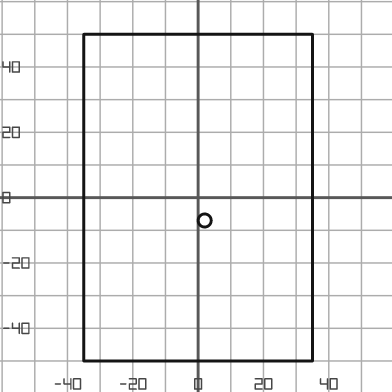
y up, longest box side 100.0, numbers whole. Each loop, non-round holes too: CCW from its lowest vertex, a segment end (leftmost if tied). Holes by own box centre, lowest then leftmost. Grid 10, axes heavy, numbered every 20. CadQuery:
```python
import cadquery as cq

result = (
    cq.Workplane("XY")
    .moveTo(-35.0, -50.0)
    .lineTo(35.0, -50.0)
    .lineTo(35.0, 50.0)
    .lineTo(-35.0, 50.0)
    .close()
    .moveTo(2.0, -7.0)
    .circle(2.0)
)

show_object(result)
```